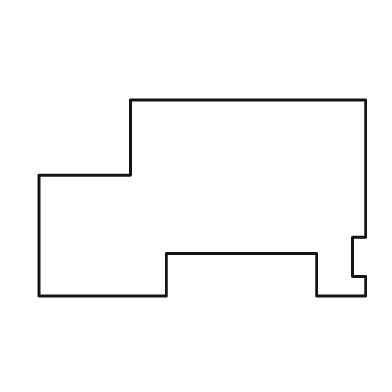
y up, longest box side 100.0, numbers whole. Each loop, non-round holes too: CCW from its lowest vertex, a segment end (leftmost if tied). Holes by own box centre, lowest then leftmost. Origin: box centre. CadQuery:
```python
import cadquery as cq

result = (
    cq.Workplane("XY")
    .moveTo(-50.0, -30.0)
    .lineTo(-11.0, -30.0)
    .lineTo(-11.0, -17.0)
    .lineTo(35.0, -17.0)
    .lineTo(35.0, -30.0)
    .lineTo(50.0, -30.0)
    .lineTo(50.0, -24.0)
    .lineTo(46.0, -24.0)
    .lineTo(46.0, -12.0)
    .lineTo(50.0, -12.0)
    .lineTo(50.0, 30.0)
    .lineTo(-22.0, 30.0)
    .lineTo(-22.0, 7.0)
    .lineTo(-50.0, 7.0)
    .close()
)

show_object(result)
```